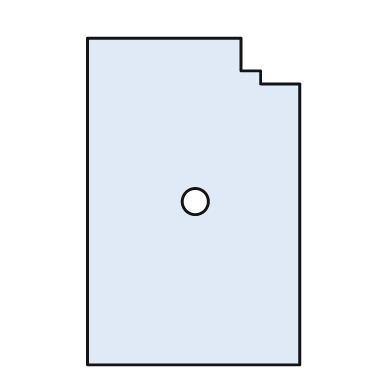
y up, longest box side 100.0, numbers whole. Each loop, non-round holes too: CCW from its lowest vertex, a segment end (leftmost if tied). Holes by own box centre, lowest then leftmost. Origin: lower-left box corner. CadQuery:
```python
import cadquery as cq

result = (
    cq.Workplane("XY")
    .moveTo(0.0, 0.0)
    .lineTo(65.0, 0.0)
    .lineTo(65.0, 86.0)
    .lineTo(53.0, 86.0)
    .lineTo(53.0, 90.0)
    .lineTo(47.0, 90.0)
    .lineTo(47.0, 100.0)
    .lineTo(0.0, 100.0)
    .close()
    .moveTo(33.0, 50.0)
    .circle(4.0)
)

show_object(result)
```